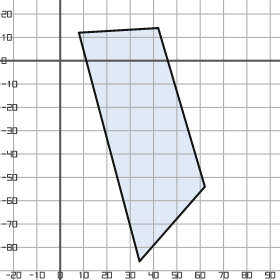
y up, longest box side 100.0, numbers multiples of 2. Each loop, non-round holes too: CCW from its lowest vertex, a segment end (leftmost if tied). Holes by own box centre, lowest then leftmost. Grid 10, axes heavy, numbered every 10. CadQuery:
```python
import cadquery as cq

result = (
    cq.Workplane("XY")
    .moveTo(34.0, -86.0)
    .lineTo(62.0, -54.0)
    .lineTo(42.0, 14.0)
    .lineTo(8.0, 12.0)
    .close()
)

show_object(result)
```